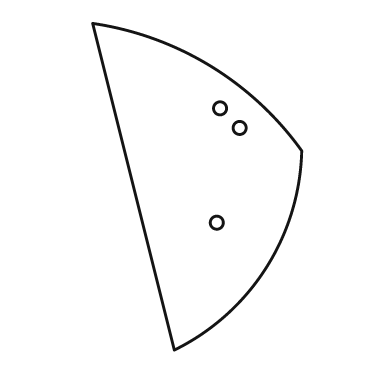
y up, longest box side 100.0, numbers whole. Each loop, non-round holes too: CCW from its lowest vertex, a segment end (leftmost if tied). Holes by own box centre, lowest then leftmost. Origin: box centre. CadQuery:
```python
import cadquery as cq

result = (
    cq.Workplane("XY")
    .moveTo(-7.0, -50.0)
    .threePointArc((21.0, -25.0), (32.0, 11.0))
    .threePointArc((4.0, 37.0), (-32.0, 50.0))
    .close()
    .moveTo(6.0, -11.0)
    .circle(2.0)
    .moveTo(13.0, 18.0)
    .circle(2.0)
    .moveTo(7.0, 24.0)
    .circle(2.0)
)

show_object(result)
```